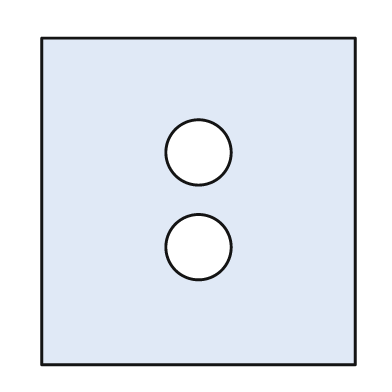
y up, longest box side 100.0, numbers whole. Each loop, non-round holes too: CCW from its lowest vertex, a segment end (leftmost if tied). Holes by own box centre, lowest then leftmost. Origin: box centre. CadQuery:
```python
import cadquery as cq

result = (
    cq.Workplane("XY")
    .moveTo(-48.0, -50.0)
    .lineTo(48.0, -50.0)
    .lineTo(48.0, 50.0)
    .lineTo(-48.0, 50.0)
    .close()
    .moveTo(0.0, -14.0)
    .circle(10.0)
    .moveTo(0.0, 15.0)
    .circle(10.0)
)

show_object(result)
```